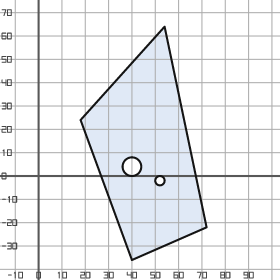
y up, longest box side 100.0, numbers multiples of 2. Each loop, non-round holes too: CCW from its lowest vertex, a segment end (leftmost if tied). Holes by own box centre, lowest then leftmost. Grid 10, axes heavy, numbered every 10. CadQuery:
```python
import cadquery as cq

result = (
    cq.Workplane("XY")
    .moveTo(40.0, -36.0)
    .lineTo(72.0, -22.0)
    .lineTo(54.0, 64.0)
    .lineTo(18.0, 24.0)
    .close()
    .moveTo(52.0, -2.0)
    .circle(2.0)
    .moveTo(40.0, 4.0)
    .circle(4.0)
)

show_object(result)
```